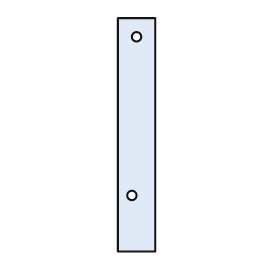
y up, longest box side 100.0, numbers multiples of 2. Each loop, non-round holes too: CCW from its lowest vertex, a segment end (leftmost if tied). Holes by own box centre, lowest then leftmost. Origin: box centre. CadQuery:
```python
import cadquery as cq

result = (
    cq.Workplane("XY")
    .moveTo(-8.0, -50.0)
    .lineTo(8.0, -50.0)
    .lineTo(8.0, 50.0)
    .lineTo(-8.0, 50.0)
    .close()
    .moveTo(-2.0, -26.0)
    .circle(2.0)
    .moveTo(0.0, 42.0)
    .circle(2.0)
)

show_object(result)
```